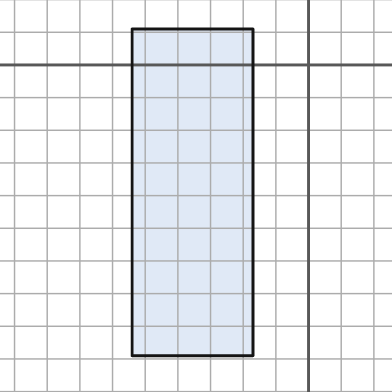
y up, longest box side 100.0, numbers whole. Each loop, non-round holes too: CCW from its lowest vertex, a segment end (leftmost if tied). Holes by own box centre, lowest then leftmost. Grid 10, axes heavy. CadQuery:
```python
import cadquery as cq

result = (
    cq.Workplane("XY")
    .moveTo(-54.0, -89.0)
    .lineTo(-17.0, -89.0)
    .lineTo(-17.0, 11.0)
    .lineTo(-54.0, 11.0)
    .close()
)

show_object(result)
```